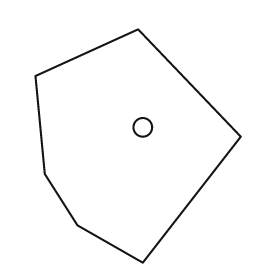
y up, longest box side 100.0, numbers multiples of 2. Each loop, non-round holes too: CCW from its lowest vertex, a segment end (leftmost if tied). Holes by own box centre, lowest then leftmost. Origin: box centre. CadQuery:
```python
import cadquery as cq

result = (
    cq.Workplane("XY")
    .moveTo(2.0, -50.0)
    .lineTo(44.0, 4.0)
    .lineTo(0.0, 50.0)
    .lineTo(-44.0, 30.0)
    .lineTo(-40.0, -12.0)
    .lineTo(-26.0, -34.0)
    .close()
    .moveTo(2.0, 8.0)
    .circle(4.0)
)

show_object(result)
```